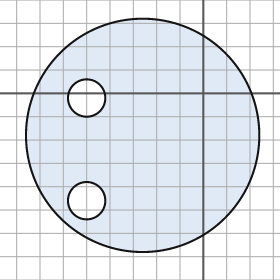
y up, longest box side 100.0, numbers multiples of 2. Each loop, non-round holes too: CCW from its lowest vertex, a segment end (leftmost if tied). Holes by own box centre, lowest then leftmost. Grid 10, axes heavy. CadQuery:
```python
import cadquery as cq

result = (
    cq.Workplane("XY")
    .moveTo(-26.0, -18.0)
    .circle(50.0)
    .moveTo(-50.0, -46.0)
    .circle(8.0)
    .moveTo(-50.0, -2.0)
    .circle(8.0)
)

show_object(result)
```